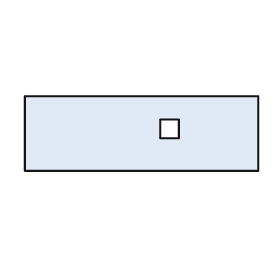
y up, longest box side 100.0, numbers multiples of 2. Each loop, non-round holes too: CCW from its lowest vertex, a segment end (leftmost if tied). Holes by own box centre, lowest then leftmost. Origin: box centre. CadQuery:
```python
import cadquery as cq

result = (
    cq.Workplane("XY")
    .moveTo(-50.0, -16.0)
    .lineTo(50.0, -16.0)
    .lineTo(50.0, 16.0)
    .lineTo(-50.0, 16.0)
    .close()
    .moveTo(8.0, -2.0)
    .lineTo(16.0, -2.0)
    .lineTo(16.0, 6.0)
    .lineTo(8.0, 6.0)
    .close()
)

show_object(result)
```